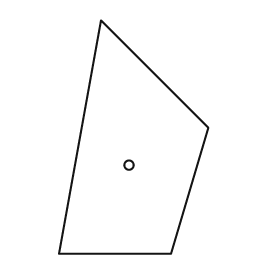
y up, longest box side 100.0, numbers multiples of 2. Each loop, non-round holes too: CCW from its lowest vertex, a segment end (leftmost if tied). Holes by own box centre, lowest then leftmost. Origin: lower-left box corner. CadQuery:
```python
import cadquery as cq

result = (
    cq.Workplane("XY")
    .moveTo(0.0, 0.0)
    .lineTo(48.0, 0.0)
    .lineTo(64.0, 54.0)
    .lineTo(18.0, 100.0)
    .close()
    .moveTo(30.0, 38.0)
    .circle(2.0)
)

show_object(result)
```